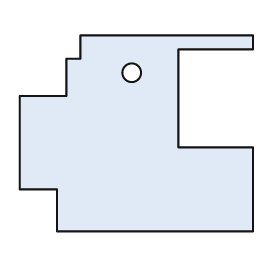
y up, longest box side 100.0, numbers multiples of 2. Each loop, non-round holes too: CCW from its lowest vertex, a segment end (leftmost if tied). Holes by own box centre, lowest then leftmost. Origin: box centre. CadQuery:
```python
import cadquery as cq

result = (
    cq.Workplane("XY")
    .moveTo(-34.0, -42.0)
    .lineTo(50.0, -42.0)
    .lineTo(50.0, -6.0)
    .lineTo(18.0, -6.0)
    .lineTo(18.0, 36.0)
    .lineTo(50.0, 36.0)
    .lineTo(50.0, 42.0)
    .lineTo(-24.0, 42.0)
    .lineTo(-24.0, 32.0)
    .lineTo(-30.0, 32.0)
    .lineTo(-30.0, 16.0)
    .lineTo(-50.0, 16.0)
    .lineTo(-50.0, -24.0)
    .lineTo(-34.0, -24.0)
    .close()
    .moveTo(-2.0, 26.0)
    .circle(4.0)
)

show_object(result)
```